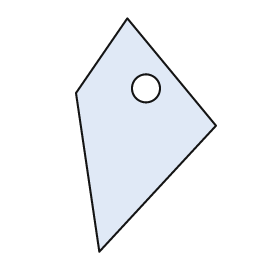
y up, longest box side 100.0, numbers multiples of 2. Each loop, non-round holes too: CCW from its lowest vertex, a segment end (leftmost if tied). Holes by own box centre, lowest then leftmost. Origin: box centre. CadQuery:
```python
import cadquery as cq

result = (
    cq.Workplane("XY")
    .moveTo(-20.0, -50.0)
    .lineTo(30.0, 4.0)
    .lineTo(-8.0, 50.0)
    .lineTo(-30.0, 18.0)
    .close()
    .moveTo(0.0, 20.0)
    .circle(6.0)
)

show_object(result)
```